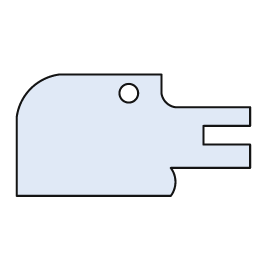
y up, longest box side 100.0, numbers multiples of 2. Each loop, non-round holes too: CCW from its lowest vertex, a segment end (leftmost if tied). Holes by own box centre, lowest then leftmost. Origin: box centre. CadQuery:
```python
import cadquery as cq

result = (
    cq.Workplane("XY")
    .moveTo(-50.0, -26.0)
    .lineTo(16.0, -26.0)
    .threePointArc((18.0, -20.0), (16.0, -14.0))
    .lineTo(50.0, -14.0)
    .lineTo(50.0, -4.0)
    .lineTo(30.0, -4.0)
    .lineTo(30.0, 4.0)
    .lineTo(50.0, 4.0)
    .lineTo(50.0, 12.0)
    .lineTo(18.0, 12.0)
    .threePointArc((14.0, 14.0), (12.0, 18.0))
    .lineTo(12.0, 26.0)
    .lineTo(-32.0, 26.0)
    .threePointArc((-44.0, 20.0), (-50.0, 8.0))
    .close()
    .moveTo(-2.0, 18.0)
    .circle(4.0)
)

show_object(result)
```